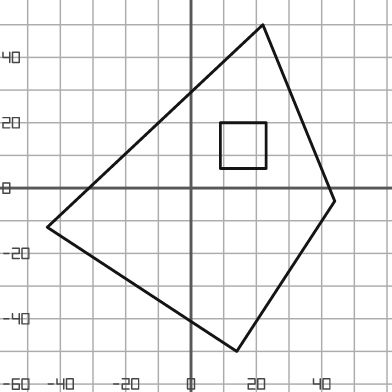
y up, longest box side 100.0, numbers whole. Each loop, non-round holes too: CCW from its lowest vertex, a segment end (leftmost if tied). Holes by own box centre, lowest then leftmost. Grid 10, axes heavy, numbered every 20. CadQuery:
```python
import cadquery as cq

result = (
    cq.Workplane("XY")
    .moveTo(14.0, -50.0)
    .lineTo(44.0, -4.0)
    .lineTo(22.0, 50.0)
    .lineTo(-44.0, -12.0)
    .close()
    .moveTo(9.0, 6.0)
    .lineTo(23.0, 6.0)
    .lineTo(23.0, 20.0)
    .lineTo(9.0, 20.0)
    .close()
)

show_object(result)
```